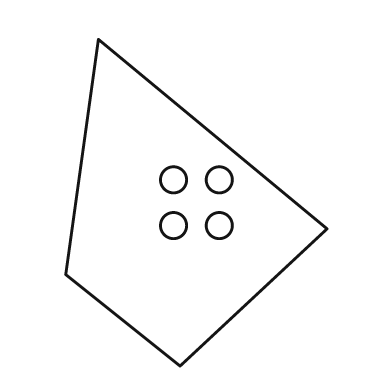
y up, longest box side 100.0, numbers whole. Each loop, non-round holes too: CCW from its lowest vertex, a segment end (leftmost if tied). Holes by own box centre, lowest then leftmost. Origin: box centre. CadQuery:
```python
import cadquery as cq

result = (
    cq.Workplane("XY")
    .moveTo(-5.0, -50.0)
    .lineTo(40.0, -8.0)
    .lineTo(-30.0, 50.0)
    .lineTo(-40.0, -22.0)
    .close()
    .moveTo(-7.0, -7.0)
    .circle(4.0)
    .moveTo(7.0, -7.0)
    .circle(4.0)
    .moveTo(-7.0, 7.0)
    .circle(4.0)
    .moveTo(7.0, 7.0)
    .circle(4.0)
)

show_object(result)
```